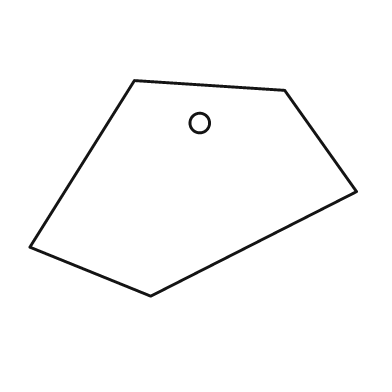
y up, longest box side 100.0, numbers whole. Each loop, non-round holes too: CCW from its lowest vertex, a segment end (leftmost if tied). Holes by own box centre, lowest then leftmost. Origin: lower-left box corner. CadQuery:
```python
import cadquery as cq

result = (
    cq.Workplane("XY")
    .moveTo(37.0, 0.0)
    .lineTo(100.0, 32.0)
    .lineTo(78.0, 63.0)
    .lineTo(32.0, 66.0)
    .lineTo(0.0, 15.0)
    .close()
    .moveTo(52.0, 53.0)
    .circle(3.0)
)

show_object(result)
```